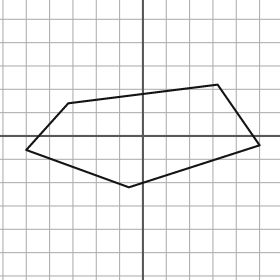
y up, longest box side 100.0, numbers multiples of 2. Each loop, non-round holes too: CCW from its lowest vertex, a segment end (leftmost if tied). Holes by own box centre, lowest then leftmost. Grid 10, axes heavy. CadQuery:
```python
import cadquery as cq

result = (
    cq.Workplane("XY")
    .moveTo(-6.0, -22.0)
    .lineTo(50.0, -4.0)
    .lineTo(32.0, 22.0)
    .lineTo(-32.0, 14.0)
    .lineTo(-50.0, -6.0)
    .close()
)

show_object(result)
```